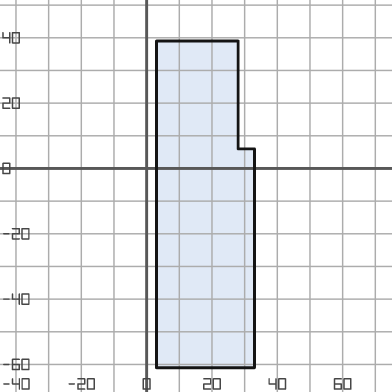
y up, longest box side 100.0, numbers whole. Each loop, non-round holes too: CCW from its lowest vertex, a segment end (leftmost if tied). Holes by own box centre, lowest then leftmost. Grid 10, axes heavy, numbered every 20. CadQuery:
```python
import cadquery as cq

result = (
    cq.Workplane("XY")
    .moveTo(3.0, -61.0)
    .lineTo(33.0, -61.0)
    .lineTo(33.0, 6.0)
    .lineTo(28.0, 6.0)
    .lineTo(28.0, 39.0)
    .lineTo(3.0, 39.0)
    .close()
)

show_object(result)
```